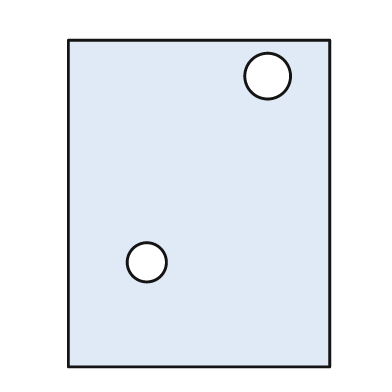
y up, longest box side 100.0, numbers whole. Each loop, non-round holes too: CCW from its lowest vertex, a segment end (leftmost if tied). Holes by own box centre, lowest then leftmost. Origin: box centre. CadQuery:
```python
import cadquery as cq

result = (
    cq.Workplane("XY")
    .moveTo(-40.0, -50.0)
    .lineTo(40.0, -50.0)
    .lineTo(40.0, 50.0)
    .lineTo(-40.0, 50.0)
    .close()
    .moveTo(-16.0, -18.0)
    .circle(6.0)
    .moveTo(21.0, 39.0)
    .circle(7.0)
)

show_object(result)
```